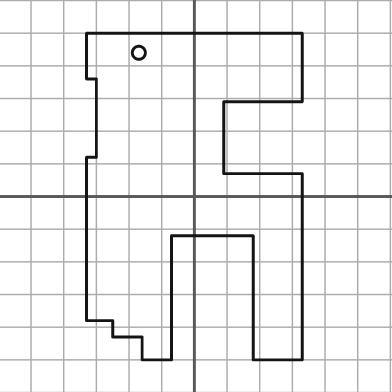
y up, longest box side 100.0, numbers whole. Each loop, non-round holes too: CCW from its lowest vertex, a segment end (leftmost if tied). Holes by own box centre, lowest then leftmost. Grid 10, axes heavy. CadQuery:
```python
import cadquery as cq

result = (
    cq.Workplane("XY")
    .moveTo(-16.0, -50.0)
    .lineTo(-7.0, -50.0)
    .lineTo(-7.0, -12.0)
    .lineTo(18.0, -12.0)
    .lineTo(18.0, -50.0)
    .lineTo(33.0, -50.0)
    .lineTo(33.0, 7.0)
    .lineTo(9.0, 7.0)
    .lineTo(9.0, 29.0)
    .lineTo(33.0, 29.0)
    .lineTo(33.0, 50.0)
    .lineTo(-33.0, 50.0)
    .lineTo(-33.0, 36.0)
    .lineTo(-30.0, 36.0)
    .lineTo(-30.0, 12.0)
    .lineTo(-33.0, 12.0)
    .lineTo(-33.0, -38.0)
    .lineTo(-25.0, -38.0)
    .lineTo(-25.0, -43.0)
    .lineTo(-16.0, -43.0)
    .close()
    .moveTo(-17.0, 44.0)
    .circle(2.0)
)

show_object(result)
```